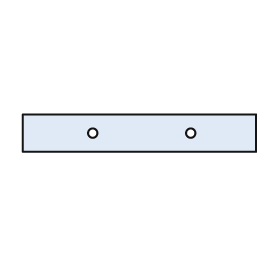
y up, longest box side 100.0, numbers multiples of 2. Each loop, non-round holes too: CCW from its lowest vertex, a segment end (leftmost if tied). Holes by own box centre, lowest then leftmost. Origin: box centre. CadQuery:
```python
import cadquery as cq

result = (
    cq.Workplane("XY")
    .moveTo(-50.0, -8.0)
    .lineTo(50.0, -8.0)
    .lineTo(50.0, 8.0)
    .lineTo(-50.0, 8.0)
    .close()
    .moveTo(-20.0, 0.0)
    .circle(2.0)
    .moveTo(22.0, 0.0)
    .circle(2.0)
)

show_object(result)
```